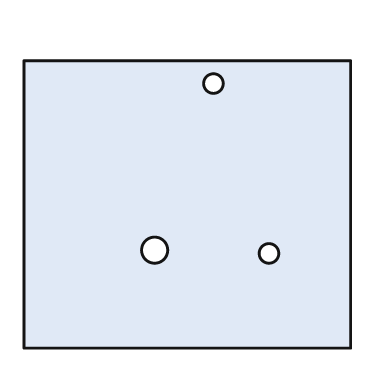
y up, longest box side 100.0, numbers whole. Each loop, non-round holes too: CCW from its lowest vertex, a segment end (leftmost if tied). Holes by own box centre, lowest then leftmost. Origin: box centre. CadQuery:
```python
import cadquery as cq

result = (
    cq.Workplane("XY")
    .moveTo(-50.0, -44.0)
    .lineTo(50.0, -44.0)
    .lineTo(50.0, 44.0)
    .lineTo(-50.0, 44.0)
    .close()
    .moveTo(25.0, -15.0)
    .circle(3.0)
    .moveTo(-10.0, -14.0)
    .circle(4.0)
    .moveTo(8.0, 37.0)
    .circle(3.0)
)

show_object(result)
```